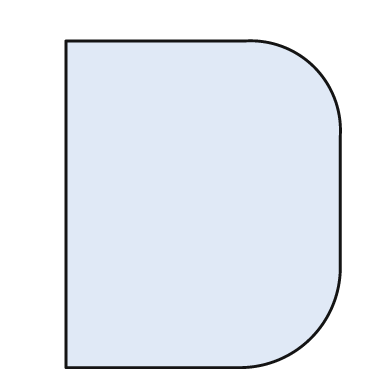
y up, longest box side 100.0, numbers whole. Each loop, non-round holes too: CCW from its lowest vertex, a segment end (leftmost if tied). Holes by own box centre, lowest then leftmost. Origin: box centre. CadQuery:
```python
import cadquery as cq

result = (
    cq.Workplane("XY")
    .moveTo(-42.0, -50.0)
    .lineTo(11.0, -50.0)
    .threePointArc((33.0, -41.0), (42.0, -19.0))
    .lineTo(42.0, 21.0)
    .threePointArc((34.0, 42.0), (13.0, 50.0))
    .lineTo(-42.0, 50.0)
    .close()
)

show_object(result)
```